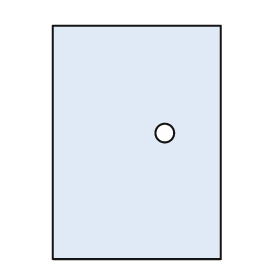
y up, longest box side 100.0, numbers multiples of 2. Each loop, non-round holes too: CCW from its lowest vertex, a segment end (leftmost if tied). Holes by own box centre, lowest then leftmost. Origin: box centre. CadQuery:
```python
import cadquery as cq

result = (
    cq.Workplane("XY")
    .moveTo(-36.0, -50.0)
    .lineTo(36.0, -50.0)
    .lineTo(36.0, 50.0)
    .lineTo(-36.0, 50.0)
    .close()
    .moveTo(12.0, 4.0)
    .circle(4.0)
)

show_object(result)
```